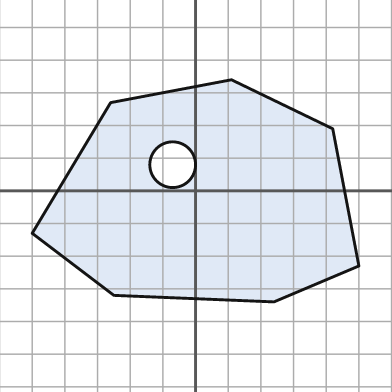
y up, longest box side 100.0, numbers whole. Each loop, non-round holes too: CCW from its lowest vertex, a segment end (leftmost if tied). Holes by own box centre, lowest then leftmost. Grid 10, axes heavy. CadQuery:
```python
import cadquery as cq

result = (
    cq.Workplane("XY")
    .moveTo(24.0, -34.0)
    .lineTo(50.0, -23.0)
    .lineTo(42.0, 19.0)
    .lineTo(11.0, 34.0)
    .lineTo(-26.0, 27.0)
    .lineTo(-50.0, -13.0)
    .lineTo(-25.0, -32.0)
    .close()
    .moveTo(-7.0, 8.0)
    .circle(7.0)
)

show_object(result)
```